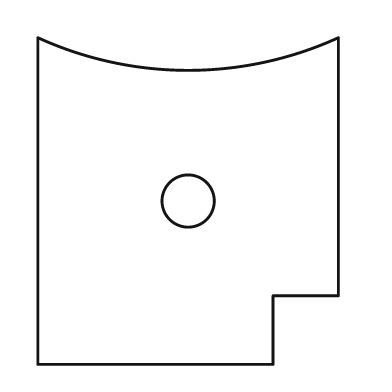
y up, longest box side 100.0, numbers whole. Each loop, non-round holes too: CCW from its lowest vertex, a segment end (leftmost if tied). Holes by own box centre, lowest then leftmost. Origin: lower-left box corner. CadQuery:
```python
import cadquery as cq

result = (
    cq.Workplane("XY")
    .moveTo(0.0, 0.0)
    .lineTo(72.0, 0.0)
    .lineTo(72.0, 21.0)
    .lineTo(92.0, 21.0)
    .lineTo(92.0, 100.0)
    .threePointArc((46.0, 90.0), (0.0, 100.0))
    .close()
    .moveTo(46.0, 50.0)
    .circle(8.0)
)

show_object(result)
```